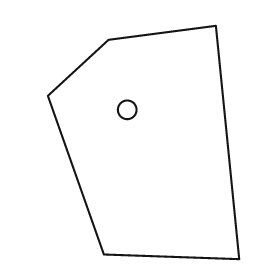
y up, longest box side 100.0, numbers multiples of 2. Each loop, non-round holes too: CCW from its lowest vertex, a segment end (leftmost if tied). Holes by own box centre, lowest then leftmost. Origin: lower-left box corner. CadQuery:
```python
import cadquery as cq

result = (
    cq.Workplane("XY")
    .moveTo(82.0, 0.0)
    .lineTo(72.0, 100.0)
    .lineTo(26.0, 94.0)
    .lineTo(0.0, 70.0)
    .lineTo(24.0, 2.0)
    .close()
    .moveTo(34.0, 64.0)
    .circle(4.0)
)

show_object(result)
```